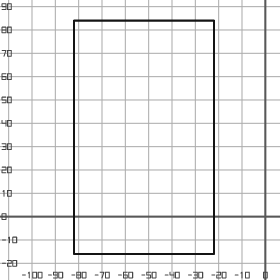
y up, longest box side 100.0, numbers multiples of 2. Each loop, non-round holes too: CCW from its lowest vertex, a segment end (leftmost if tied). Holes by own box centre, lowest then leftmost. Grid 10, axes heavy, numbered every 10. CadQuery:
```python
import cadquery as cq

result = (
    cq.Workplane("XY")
    .moveTo(-82.0, -16.0)
    .lineTo(-22.0, -16.0)
    .lineTo(-22.0, 84.0)
    .lineTo(-82.0, 84.0)
    .close()
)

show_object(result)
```